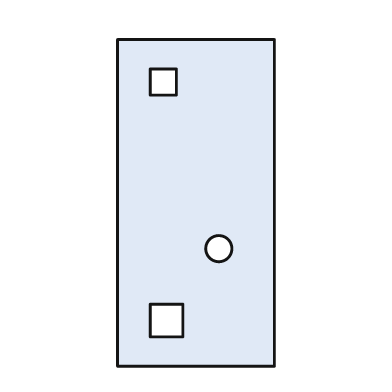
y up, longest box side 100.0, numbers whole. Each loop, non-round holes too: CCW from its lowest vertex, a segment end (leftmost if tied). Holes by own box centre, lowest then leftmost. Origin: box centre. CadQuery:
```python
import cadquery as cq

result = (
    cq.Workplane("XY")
    .moveTo(-24.0, -50.0)
    .lineTo(24.0, -50.0)
    .lineTo(24.0, 50.0)
    .lineTo(-24.0, 50.0)
    .close()
    .moveTo(-14.0, -41.0)
    .lineTo(-4.0, -41.0)
    .lineTo(-4.0, -31.0)
    .lineTo(-14.0, -31.0)
    .close()
    .moveTo(7.0, -14.0)
    .circle(4.0)
    .moveTo(-14.0, 33.0)
    .lineTo(-6.0, 33.0)
    .lineTo(-6.0, 41.0)
    .lineTo(-14.0, 41.0)
    .close()
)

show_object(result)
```